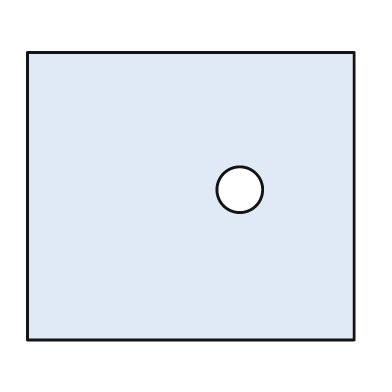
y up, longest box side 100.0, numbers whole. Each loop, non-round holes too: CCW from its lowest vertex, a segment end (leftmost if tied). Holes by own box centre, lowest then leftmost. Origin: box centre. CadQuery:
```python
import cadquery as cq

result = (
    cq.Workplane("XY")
    .moveTo(-50.0, -44.0)
    .lineTo(50.0, -44.0)
    .lineTo(50.0, 44.0)
    .lineTo(-50.0, 44.0)
    .close()
    .moveTo(15.0, 2.0)
    .circle(7.0)
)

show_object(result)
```